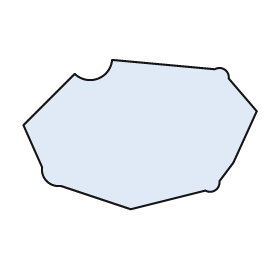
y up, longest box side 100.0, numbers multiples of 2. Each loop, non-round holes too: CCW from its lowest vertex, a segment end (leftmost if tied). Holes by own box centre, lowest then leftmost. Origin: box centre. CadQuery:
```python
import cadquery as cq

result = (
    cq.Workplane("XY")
    .moveTo(-4.0, -32.0)
    .lineTo(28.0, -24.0)
    .threePointArc((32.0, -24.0), (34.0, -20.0))
    .lineTo(40.0, -12.0)
    .lineTo(50.0, 10.0)
    .lineTo(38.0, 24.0)
    .threePointArc((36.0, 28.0), (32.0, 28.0))
    .lineTo(-12.0, 32.0)
    .threePointArc((-18.0, 24.0), (-28.0, 26.0))
    .lineTo(-50.0, 4.0)
    .lineTo(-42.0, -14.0)
    .threePointArc((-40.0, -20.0), (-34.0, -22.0))
    .close()
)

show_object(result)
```